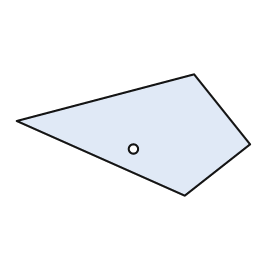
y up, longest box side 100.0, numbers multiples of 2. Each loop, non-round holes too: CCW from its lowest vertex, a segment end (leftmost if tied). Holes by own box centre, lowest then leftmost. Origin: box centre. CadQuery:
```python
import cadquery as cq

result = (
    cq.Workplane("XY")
    .moveTo(22.0, -26.0)
    .lineTo(50.0, -4.0)
    .lineTo(26.0, 26.0)
    .lineTo(-50.0, 6.0)
    .close()
    .moveTo(0.0, -6.0)
    .circle(2.0)
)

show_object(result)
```